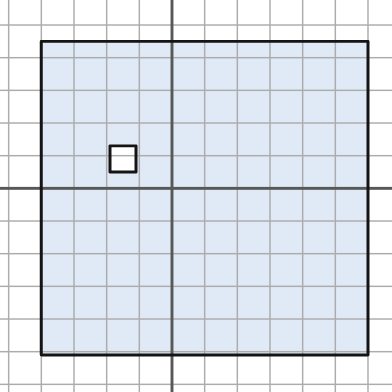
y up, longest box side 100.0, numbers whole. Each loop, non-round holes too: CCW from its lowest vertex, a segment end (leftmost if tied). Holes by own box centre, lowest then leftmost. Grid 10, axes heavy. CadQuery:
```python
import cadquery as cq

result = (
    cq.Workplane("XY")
    .moveTo(-40.0, -51.0)
    .lineTo(60.0, -51.0)
    .lineTo(60.0, 45.0)
    .lineTo(-40.0, 45.0)
    .close()
    .moveTo(-19.0, 5.0)
    .lineTo(-11.0, 5.0)
    .lineTo(-11.0, 13.0)
    .lineTo(-19.0, 13.0)
    .close()
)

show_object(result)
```